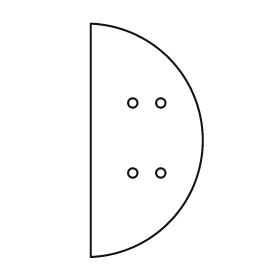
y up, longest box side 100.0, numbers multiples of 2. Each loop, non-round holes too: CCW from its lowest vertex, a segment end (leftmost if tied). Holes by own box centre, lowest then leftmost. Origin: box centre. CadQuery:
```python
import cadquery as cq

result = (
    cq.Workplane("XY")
    .moveTo(-24.0, -50.0)
    .threePointArc((24.0, 0.0), (-24.0, 50.0))
    .close()
    .moveTo(-6.0, -14.0)
    .circle(2.0)
    .moveTo(6.0, -14.0)
    .circle(2.0)
    .moveTo(-6.0, 16.0)
    .circle(2.0)
    .moveTo(6.0, 16.0)
    .circle(2.0)
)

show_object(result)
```